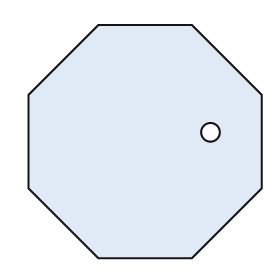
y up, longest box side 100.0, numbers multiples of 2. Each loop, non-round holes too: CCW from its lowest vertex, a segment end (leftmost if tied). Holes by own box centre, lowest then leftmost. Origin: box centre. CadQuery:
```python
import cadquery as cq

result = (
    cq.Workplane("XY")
    .moveTo(-20.0, -50.0)
    .lineTo(20.0, -50.0)
    .lineTo(50.0, -20.0)
    .lineTo(50.0, 20.0)
    .lineTo(20.0, 50.0)
    .lineTo(-20.0, 50.0)
    .lineTo(-50.0, 20.0)
    .lineTo(-50.0, -20.0)
    .close()
    .moveTo(28.0, 4.0)
    .circle(4.0)
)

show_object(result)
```